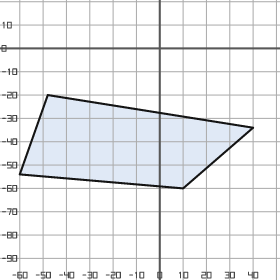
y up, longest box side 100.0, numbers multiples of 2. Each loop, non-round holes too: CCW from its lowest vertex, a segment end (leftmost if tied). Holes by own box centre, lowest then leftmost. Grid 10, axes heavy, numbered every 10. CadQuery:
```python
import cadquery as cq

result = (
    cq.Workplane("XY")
    .moveTo(10.0, -60.0)
    .lineTo(40.0, -34.0)
    .lineTo(-48.0, -20.0)
    .lineTo(-60.0, -54.0)
    .close()
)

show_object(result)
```